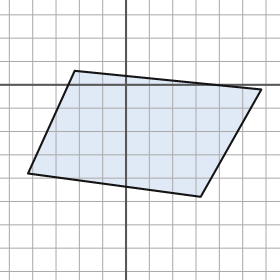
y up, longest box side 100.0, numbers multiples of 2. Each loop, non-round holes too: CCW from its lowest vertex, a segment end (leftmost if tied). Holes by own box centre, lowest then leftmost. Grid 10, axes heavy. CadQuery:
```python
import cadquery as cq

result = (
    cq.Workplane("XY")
    .moveTo(32.0, -48.0)
    .lineTo(58.0, -2.0)
    .lineTo(-22.0, 6.0)
    .lineTo(-42.0, -38.0)
    .close()
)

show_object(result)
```